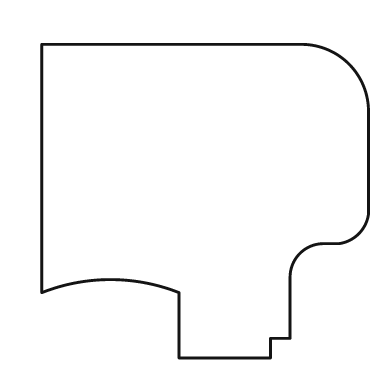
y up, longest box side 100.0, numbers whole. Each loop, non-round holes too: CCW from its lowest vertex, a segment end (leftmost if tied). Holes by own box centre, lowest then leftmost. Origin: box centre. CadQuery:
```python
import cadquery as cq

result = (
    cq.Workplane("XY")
    .moveTo(-8.0, -48.0)
    .lineTo(20.0, -48.0)
    .lineTo(20.0, -42.0)
    .lineTo(26.0, -42.0)
    .lineTo(26.0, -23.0)
    .threePointArc((29.0, -16.0), (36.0, -13.0))
    .lineTo(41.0, -13.0)
    .threePointArc((47.0, -10.0), (50.0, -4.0))
    .lineTo(50.0, 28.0)
    .threePointArc((44.0, 42.0), (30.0, 48.0))
    .lineTo(-50.0, 48.0)
    .lineTo(-50.0, -28.0)
    .threePointArc((-29.0, -24.0), (-8.0, -28.0))
    .close()
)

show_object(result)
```